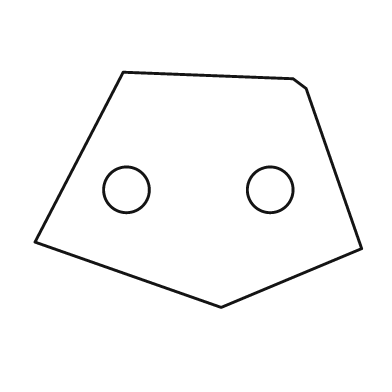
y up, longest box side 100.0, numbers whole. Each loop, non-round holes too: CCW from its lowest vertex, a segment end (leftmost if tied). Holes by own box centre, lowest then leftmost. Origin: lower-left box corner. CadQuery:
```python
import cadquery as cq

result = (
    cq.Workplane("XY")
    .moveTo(57.0, 0.0)
    .lineTo(100.0, 18.0)
    .lineTo(83.0, 67.0)
    .lineTo(79.0, 70.0)
    .lineTo(27.0, 72.0)
    .lineTo(0.0, 20.0)
    .close()
    .moveTo(28.0, 36.0)
    .circle(7.0)
    .moveTo(72.0, 36.0)
    .circle(7.0)
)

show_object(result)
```